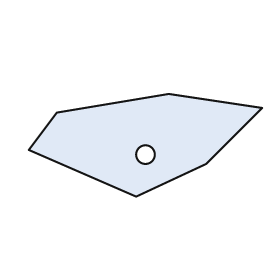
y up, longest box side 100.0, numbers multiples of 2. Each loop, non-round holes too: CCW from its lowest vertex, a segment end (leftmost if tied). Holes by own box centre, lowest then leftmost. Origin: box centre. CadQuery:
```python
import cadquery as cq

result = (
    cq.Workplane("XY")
    .moveTo(-4.0, -22.0)
    .lineTo(26.0, -8.0)
    .lineTo(50.0, 16.0)
    .lineTo(10.0, 22.0)
    .lineTo(-38.0, 14.0)
    .lineTo(-50.0, -2.0)
    .close()
    .moveTo(0.0, -4.0)
    .circle(4.0)
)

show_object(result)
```